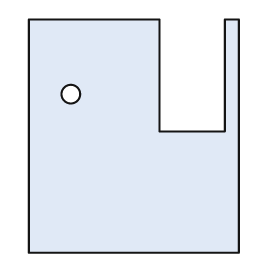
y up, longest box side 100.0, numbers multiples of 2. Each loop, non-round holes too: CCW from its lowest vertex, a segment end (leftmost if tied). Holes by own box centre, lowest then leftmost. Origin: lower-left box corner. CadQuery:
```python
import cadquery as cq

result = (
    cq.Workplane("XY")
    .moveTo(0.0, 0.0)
    .lineTo(90.0, 0.0)
    .lineTo(90.0, 100.0)
    .lineTo(84.0, 100.0)
    .lineTo(84.0, 52.0)
    .lineTo(56.0, 52.0)
    .lineTo(56.0, 100.0)
    .lineTo(0.0, 100.0)
    .close()
    .moveTo(18.0, 68.0)
    .circle(4.0)
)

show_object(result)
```